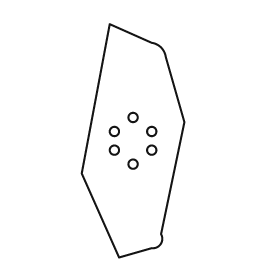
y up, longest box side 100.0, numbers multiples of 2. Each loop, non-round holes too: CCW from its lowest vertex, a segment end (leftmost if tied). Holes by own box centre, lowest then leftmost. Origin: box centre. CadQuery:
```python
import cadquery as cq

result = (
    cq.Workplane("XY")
    .moveTo(-6.0, -50.0)
    .lineTo(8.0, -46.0)
    .threePointArc((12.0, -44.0), (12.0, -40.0))
    .lineTo(22.0, 8.0)
    .lineTo(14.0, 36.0)
    .threePointArc((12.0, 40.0), (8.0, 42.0))
    .lineTo(-10.0, 50.0)
    .lineTo(-22.0, -14.0)
    .close()
    .moveTo(0.0, -10.0)
    .circle(2.0)
    .moveTo(-8.0, -4.0)
    .circle(2.0)
    .moveTo(8.0, -4.0)
    .circle(2.0)
    .moveTo(-8.0, 4.0)
    .circle(2.0)
    .moveTo(8.0, 4.0)
    .circle(2.0)
    .moveTo(0.0, 10.0)
    .circle(2.0)
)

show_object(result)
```